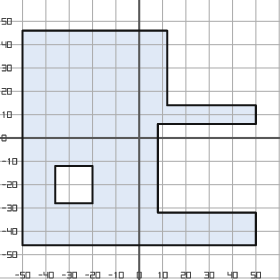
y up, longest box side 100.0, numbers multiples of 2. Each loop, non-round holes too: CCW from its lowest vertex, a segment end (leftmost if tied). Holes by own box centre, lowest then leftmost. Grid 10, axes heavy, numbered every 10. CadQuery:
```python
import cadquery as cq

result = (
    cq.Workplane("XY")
    .moveTo(-50.0, -46.0)
    .lineTo(50.0, -46.0)
    .lineTo(50.0, -32.0)
    .lineTo(8.0, -32.0)
    .lineTo(8.0, 6.0)
    .lineTo(50.0, 6.0)
    .lineTo(50.0, 14.0)
    .lineTo(12.0, 14.0)
    .lineTo(12.0, 46.0)
    .lineTo(-50.0, 46.0)
    .close()
    .moveTo(-36.0, -28.0)
    .lineTo(-20.0, -28.0)
    .lineTo(-20.0, -12.0)
    .lineTo(-36.0, -12.0)
    .close()
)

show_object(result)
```